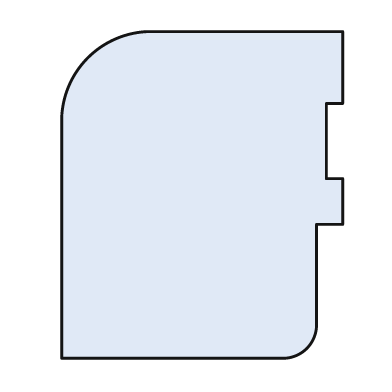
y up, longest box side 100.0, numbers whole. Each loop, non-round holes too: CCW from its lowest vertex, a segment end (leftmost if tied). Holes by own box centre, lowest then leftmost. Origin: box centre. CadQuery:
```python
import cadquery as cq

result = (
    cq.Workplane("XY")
    .moveTo(-43.0, -50.0)
    .lineTo(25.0, -50.0)
    .threePointArc((32.0, -47.0), (35.0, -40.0))
    .lineTo(35.0, -9.0)
    .lineTo(43.0, -9.0)
    .lineTo(43.0, 5.0)
    .lineTo(38.0, 5.0)
    .lineTo(38.0, 28.0)
    .lineTo(43.0, 28.0)
    .lineTo(43.0, 50.0)
    .lineTo(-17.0, 50.0)
    .threePointArc((-35.0, 42.0), (-43.0, 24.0))
    .close()
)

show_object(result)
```